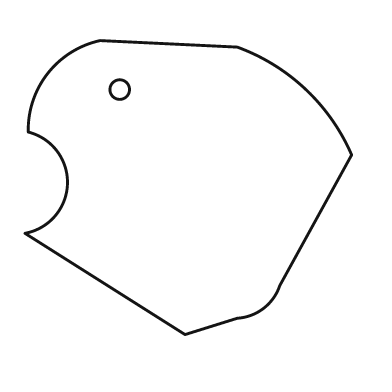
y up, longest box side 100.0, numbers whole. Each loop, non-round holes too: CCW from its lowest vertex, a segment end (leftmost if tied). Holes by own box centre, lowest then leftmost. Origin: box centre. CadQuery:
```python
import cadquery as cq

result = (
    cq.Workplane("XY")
    .moveTo(-1.0, -45.0)
    .lineTo(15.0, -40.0)
    .threePointArc((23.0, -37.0), (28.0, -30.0))
    .lineTo(50.0, 10.0)
    .threePointArc((36.0, 30.0), (15.0, 43.0))
    .lineTo(-27.0, 45.0)
    .threePointArc((-43.0, 35.0), (-49.0, 17.0))
    .threePointArc((-37.0, 1.0), (-50.0, -14.0))
    .close()
    .moveTo(-21.0, 30.0)
    .circle(3.0)
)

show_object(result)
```